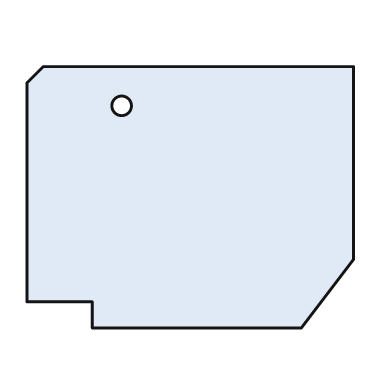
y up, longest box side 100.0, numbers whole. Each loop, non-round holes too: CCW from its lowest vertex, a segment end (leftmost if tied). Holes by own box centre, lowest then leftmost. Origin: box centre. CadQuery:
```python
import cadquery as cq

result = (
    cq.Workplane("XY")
    .moveTo(-30.0, -40.0)
    .lineTo(34.0, -40.0)
    .lineTo(50.0, -19.0)
    .lineTo(50.0, 40.0)
    .lineTo(-45.0, 40.0)
    .lineTo(-50.0, 35.0)
    .lineTo(-50.0, -32.0)
    .lineTo(-30.0, -32.0)
    .close()
    .moveTo(-21.0, 28.0)
    .circle(3.0)
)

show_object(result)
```